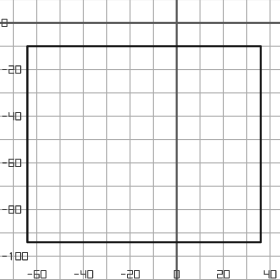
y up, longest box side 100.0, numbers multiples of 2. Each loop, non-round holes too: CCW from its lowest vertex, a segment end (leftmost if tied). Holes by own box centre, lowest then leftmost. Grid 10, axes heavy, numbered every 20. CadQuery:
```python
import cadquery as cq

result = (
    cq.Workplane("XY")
    .moveTo(-64.0, -94.0)
    .lineTo(36.0, -94.0)
    .lineTo(36.0, -10.0)
    .lineTo(-64.0, -10.0)
    .close()
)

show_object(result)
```